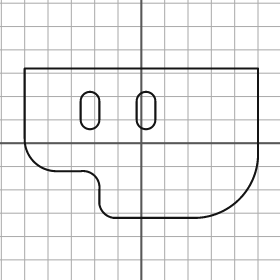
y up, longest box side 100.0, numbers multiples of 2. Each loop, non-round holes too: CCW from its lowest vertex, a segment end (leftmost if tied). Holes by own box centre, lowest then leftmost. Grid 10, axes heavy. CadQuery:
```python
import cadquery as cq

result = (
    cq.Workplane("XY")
    .moveTo(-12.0, -32.0)
    .lineTo(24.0, -32.0)
    .threePointArc((42.0, -24.0), (50.0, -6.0))
    .lineTo(50.0, 32.0)
    .lineTo(-50.0, 32.0)
    .lineTo(-50.0, 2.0)
    .threePointArc((-46.0, -8.0), (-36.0, -12.0))
    .lineTo(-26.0, -12.0)
    .threePointArc((-20.0, -14.0), (-18.0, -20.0))
    .lineTo(-18.0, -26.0)
    .threePointArc((-16.0, -30.0), (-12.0, -32.0))
    .close()
    .moveTo(-26.0, 10.0)
    .threePointArc((-22.0, 6.0), (-18.0, 10.0))
    .lineTo(-18.0, 18.0)
    .threePointArc((-22.0, 22.0), (-26.0, 18.0))
    .close()
    .moveTo(-2.0, 10.0)
    .threePointArc((2.0, 6.0), (6.0, 10.0))
    .lineTo(6.0, 18.0)
    .threePointArc((2.0, 22.0), (-2.0, 18.0))
    .close()
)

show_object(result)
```